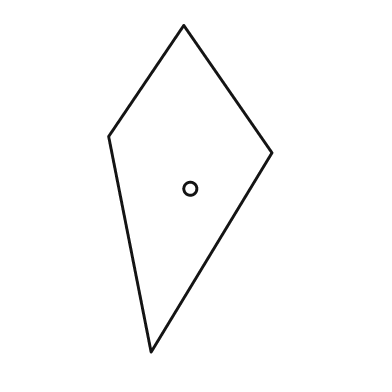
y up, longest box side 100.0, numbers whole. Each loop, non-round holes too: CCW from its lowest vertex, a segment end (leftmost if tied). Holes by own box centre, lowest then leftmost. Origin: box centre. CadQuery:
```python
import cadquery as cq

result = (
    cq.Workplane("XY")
    .moveTo(-12.0, -50.0)
    .lineTo(25.0, 11.0)
    .lineTo(-2.0, 50.0)
    .lineTo(-25.0, 16.0)
    .close()
    .moveTo(0.0, 0.0)
    .circle(2.0)
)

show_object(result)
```